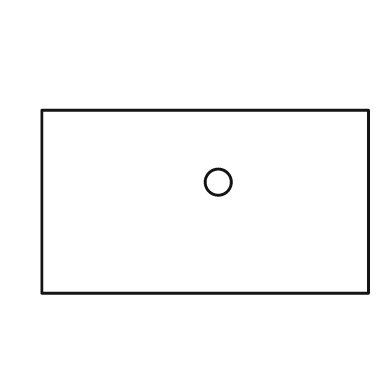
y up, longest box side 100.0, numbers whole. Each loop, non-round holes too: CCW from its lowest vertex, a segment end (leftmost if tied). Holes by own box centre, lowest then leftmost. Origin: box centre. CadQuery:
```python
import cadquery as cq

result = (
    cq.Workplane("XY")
    .moveTo(-50.0, -28.0)
    .lineTo(50.0, -28.0)
    .lineTo(50.0, 28.0)
    .lineTo(-50.0, 28.0)
    .close()
    .moveTo(4.0, 6.0)
    .circle(4.0)
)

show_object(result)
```